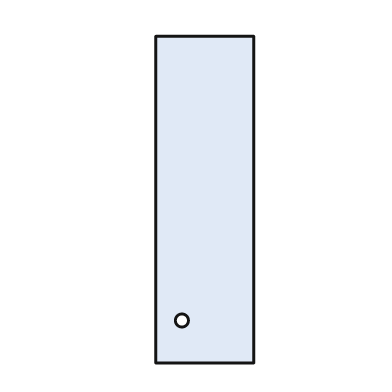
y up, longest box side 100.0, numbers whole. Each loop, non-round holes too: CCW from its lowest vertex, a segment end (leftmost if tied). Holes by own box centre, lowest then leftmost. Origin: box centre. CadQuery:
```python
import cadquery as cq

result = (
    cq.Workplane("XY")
    .moveTo(-15.0, -50.0)
    .lineTo(15.0, -50.0)
    .lineTo(15.0, 50.0)
    .lineTo(-15.0, 50.0)
    .close()
    .moveTo(-7.0, -37.0)
    .circle(2.0)
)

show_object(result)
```